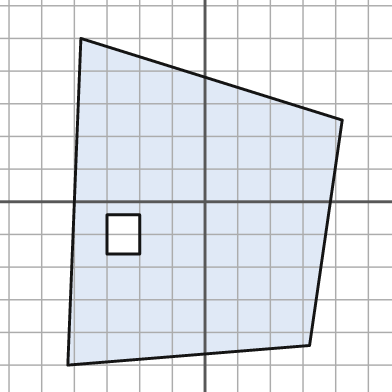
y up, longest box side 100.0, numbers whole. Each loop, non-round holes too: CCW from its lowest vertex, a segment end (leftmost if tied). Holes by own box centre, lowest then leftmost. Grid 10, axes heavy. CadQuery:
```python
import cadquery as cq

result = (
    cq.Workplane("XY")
    .moveTo(-42.0, -50.0)
    .lineTo(32.0, -44.0)
    .lineTo(42.0, 25.0)
    .lineTo(-38.0, 50.0)
    .close()
    .moveTo(-30.0, -16.0)
    .lineTo(-20.0, -16.0)
    .lineTo(-20.0, -4.0)
    .lineTo(-30.0, -4.0)
    .close()
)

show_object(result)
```